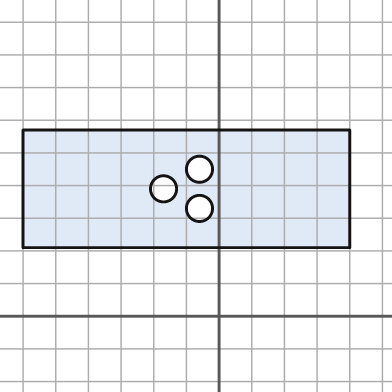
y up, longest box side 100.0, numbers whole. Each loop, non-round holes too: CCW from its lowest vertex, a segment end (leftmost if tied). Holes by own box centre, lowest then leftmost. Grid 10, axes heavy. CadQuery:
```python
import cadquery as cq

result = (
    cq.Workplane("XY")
    .moveTo(-60.0, 21.0)
    .lineTo(40.0, 21.0)
    .lineTo(40.0, 57.0)
    .lineTo(-60.0, 57.0)
    .close()
    .moveTo(-6.0, 33.0)
    .circle(4.0)
    .moveTo(-17.0, 39.0)
    .circle(4.0)
    .moveTo(-6.0, 45.0)
    .circle(4.0)
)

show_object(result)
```